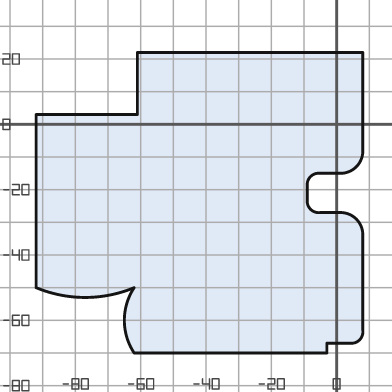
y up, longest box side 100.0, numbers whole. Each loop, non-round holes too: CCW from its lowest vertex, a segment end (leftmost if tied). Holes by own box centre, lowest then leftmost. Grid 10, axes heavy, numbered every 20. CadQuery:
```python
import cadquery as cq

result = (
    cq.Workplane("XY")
    .moveTo(-62.0, -70.0)
    .lineTo(-3.0, -70.0)
    .lineTo(-3.0, -67.0)
    .lineTo(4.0, -67.0)
    .threePointArc((7.0, -66.0), (8.0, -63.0))
    .lineTo(8.0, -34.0)
    .threePointArc((6.0, -29.0), (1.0, -27.0))
    .lineTo(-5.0, -27.0)
    .threePointArc((-8.0, -26.0), (-9.0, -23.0))
    .lineTo(-9.0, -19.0)
    .threePointArc((-8.0, -16.0), (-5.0, -15.0))
    .lineTo(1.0, -15.0)
    .threePointArc((6.0, -13.0), (8.0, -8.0))
    .lineTo(8.0, 22.0)
    .lineTo(-61.0, 22.0)
    .lineTo(-61.0, 3.0)
    .lineTo(-92.0, 3.0)
    .lineTo(-92.0, -50.0)
    .threePointArc((-77.0, -53.0), (-62.0, -50.0))
    .threePointArc((-65.0, -60.0), (-62.0, -70.0))
    .close()
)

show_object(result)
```